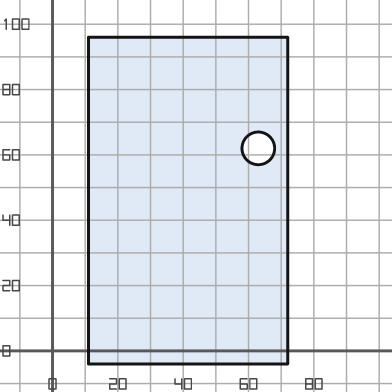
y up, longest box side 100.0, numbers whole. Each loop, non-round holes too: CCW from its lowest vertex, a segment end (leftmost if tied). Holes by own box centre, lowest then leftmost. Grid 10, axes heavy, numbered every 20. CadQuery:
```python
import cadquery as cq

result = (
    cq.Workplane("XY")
    .moveTo(11.0, -4.0)
    .lineTo(72.0, -4.0)
    .lineTo(72.0, 96.0)
    .lineTo(11.0, 96.0)
    .close()
    .moveTo(63.0, 62.0)
    .circle(5.0)
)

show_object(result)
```